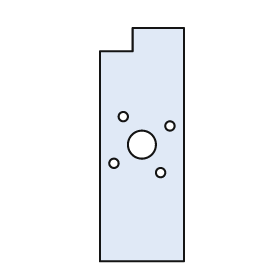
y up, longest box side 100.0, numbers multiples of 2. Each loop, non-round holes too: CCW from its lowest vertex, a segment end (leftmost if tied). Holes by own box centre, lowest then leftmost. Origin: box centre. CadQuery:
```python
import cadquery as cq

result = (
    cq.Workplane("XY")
    .moveTo(-18.0, -50.0)
    .lineTo(18.0, -50.0)
    .lineTo(18.0, 50.0)
    .lineTo(-4.0, 50.0)
    .lineTo(-4.0, 40.0)
    .lineTo(-18.0, 40.0)
    .close()
    .moveTo(8.0, -12.0)
    .circle(2.0)
    .moveTo(-12.0, -8.0)
    .circle(2.0)
    .moveTo(0.0, 0.0)
    .circle(6.0)
    .moveTo(12.0, 8.0)
    .circle(2.0)
    .moveTo(-8.0, 12.0)
    .circle(2.0)
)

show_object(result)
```